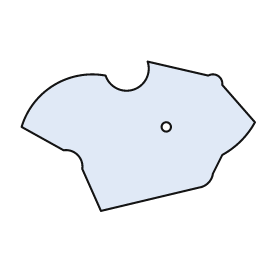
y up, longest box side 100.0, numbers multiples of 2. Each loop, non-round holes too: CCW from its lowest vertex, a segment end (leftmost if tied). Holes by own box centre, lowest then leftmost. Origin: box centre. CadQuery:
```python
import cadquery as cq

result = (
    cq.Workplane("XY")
    .moveTo(-16.0, -32.0)
    .lineTo(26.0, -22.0)
    .threePointArc((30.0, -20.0), (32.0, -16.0))
    .lineTo(36.0, -8.0)
    .threePointArc((44.0, -2.0), (50.0, 6.0))
    .lineTo(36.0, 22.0)
    .threePointArc((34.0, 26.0), (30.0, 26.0))
    .lineTo(4.0, 32.0)
    .threePointArc((-2.0, 20.0), (-14.0, 26.0))
    .threePointArc((-36.0, 22.0), (-50.0, 4.0))
    .lineTo(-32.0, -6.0)
    .threePointArc((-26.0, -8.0), (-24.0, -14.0))
    .close()
    .moveTo(12.0, 4.0)
    .circle(2.0)
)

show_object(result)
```